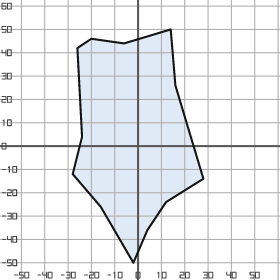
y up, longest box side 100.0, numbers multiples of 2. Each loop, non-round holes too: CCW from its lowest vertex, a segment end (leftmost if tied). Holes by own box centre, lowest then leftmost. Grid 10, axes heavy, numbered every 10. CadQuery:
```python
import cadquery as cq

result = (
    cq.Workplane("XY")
    .moveTo(-2.0, -50.0)
    .lineTo(4.0, -36.0)
    .lineTo(12.0, -24.0)
    .lineTo(28.0, -14.0)
    .lineTo(16.0, 26.0)
    .lineTo(14.0, 50.0)
    .lineTo(-6.0, 44.0)
    .lineTo(-20.0, 46.0)
    .lineTo(-26.0, 42.0)
    .lineTo(-24.0, 4.0)
    .lineTo(-28.0, -12.0)
    .lineTo(-16.0, -26.0)
    .close()
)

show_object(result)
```